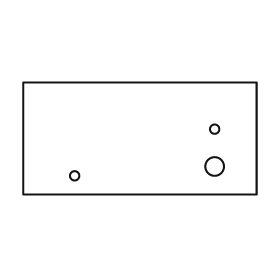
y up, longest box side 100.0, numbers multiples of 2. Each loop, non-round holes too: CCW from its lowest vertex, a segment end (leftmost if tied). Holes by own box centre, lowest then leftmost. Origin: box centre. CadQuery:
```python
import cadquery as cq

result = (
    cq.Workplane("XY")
    .moveTo(-50.0, -24.0)
    .lineTo(50.0, -24.0)
    .lineTo(50.0, 24.0)
    .lineTo(-50.0, 24.0)
    .close()
    .moveTo(-28.0, -16.0)
    .circle(2.0)
    .moveTo(32.0, -12.0)
    .circle(4.0)
    .moveTo(32.0, 4.0)
    .circle(2.0)
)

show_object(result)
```